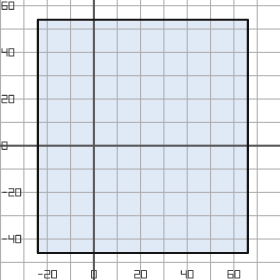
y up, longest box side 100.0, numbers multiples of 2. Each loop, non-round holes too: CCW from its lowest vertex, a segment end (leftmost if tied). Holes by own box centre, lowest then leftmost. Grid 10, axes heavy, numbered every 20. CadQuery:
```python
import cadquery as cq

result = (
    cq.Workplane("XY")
    .moveTo(-24.0, -46.0)
    .lineTo(66.0, -46.0)
    .lineTo(66.0, 54.0)
    .lineTo(-24.0, 54.0)
    .close()
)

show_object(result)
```